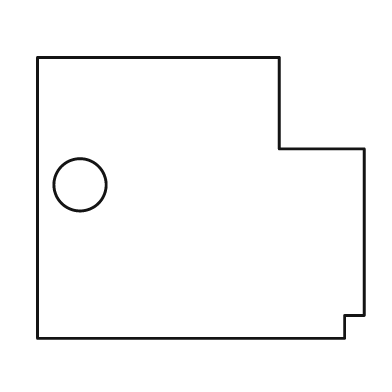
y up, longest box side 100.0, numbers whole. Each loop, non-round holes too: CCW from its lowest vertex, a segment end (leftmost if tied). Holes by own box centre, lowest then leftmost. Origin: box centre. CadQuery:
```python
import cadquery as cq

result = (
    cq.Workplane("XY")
    .moveTo(-50.0, -43.0)
    .lineTo(44.0, -43.0)
    .lineTo(44.0, -36.0)
    .lineTo(50.0, -36.0)
    .lineTo(50.0, 15.0)
    .lineTo(24.0, 15.0)
    .lineTo(24.0, 43.0)
    .lineTo(-50.0, 43.0)
    .close()
    .moveTo(-37.0, 4.0)
    .circle(8.0)
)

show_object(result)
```